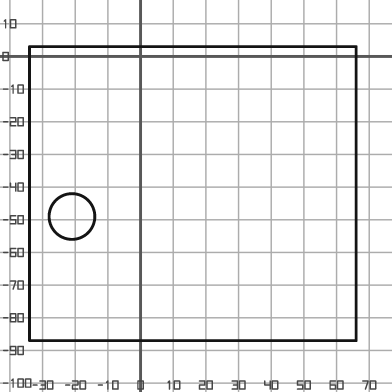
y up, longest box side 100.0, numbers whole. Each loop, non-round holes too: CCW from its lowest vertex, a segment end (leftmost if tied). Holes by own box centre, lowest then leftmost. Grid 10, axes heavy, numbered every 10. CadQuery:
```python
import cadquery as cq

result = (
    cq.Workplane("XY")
    .moveTo(-34.0, -87.0)
    .lineTo(66.0, -87.0)
    .lineTo(66.0, 3.0)
    .lineTo(-34.0, 3.0)
    .close()
    .moveTo(-21.0, -49.0)
    .circle(7.0)
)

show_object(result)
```